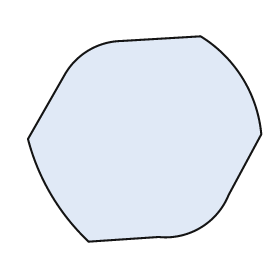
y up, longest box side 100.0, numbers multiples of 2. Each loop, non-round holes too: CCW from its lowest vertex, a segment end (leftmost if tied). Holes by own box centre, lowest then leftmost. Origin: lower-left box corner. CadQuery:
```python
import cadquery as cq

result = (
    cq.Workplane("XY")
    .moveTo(26.0, 0.0)
    .lineTo(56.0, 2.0)
    .threePointArc((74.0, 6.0), (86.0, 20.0))
    .lineTo(100.0, 46.0)
    .threePointArc((92.0, 70.0), (74.0, 88.0))
    .lineTo(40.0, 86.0)
    .threePointArc((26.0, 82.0), (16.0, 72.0))
    .lineTo(0.0, 44.0)
    .threePointArc((10.0, 20.0), (26.0, 0.0))
    .close()
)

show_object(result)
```